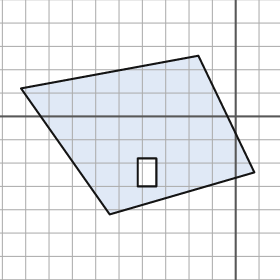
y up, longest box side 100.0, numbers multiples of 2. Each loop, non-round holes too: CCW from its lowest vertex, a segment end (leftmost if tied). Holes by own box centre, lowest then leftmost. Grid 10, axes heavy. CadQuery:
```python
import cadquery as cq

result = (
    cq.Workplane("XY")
    .moveTo(-54.0, -42.0)
    .lineTo(8.0, -24.0)
    .lineTo(-16.0, 26.0)
    .lineTo(-92.0, 12.0)
    .close()
    .moveTo(-42.0, -30.0)
    .lineTo(-34.0, -30.0)
    .lineTo(-34.0, -18.0)
    .lineTo(-42.0, -18.0)
    .close()
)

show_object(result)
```